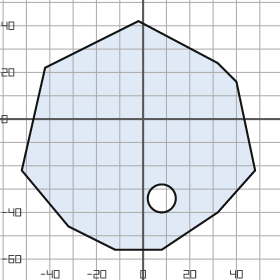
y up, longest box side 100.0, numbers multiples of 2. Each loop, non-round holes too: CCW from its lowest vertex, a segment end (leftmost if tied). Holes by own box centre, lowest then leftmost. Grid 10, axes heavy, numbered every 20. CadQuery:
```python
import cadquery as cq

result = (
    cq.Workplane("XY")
    .moveTo(-12.0, -56.0)
    .lineTo(8.0, -56.0)
    .lineTo(32.0, -40.0)
    .lineTo(48.0, -22.0)
    .lineTo(40.0, 16.0)
    .lineTo(32.0, 24.0)
    .lineTo(-2.0, 42.0)
    .lineTo(-42.0, 22.0)
    .lineTo(-52.0, -22.0)
    .lineTo(-32.0, -46.0)
    .close()
    .moveTo(8.0, -34.0)
    .circle(6.0)
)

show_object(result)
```